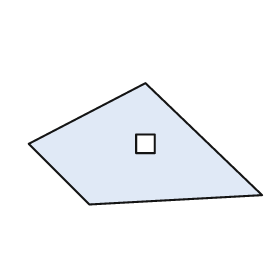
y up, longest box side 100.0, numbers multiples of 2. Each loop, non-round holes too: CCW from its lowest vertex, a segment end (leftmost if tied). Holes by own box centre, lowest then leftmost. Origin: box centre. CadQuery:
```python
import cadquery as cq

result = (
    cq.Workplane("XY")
    .moveTo(-24.0, -26.0)
    .lineTo(50.0, -22.0)
    .lineTo(0.0, 26.0)
    .lineTo(-50.0, 0.0)
    .close()
    .moveTo(-4.0, -4.0)
    .lineTo(4.0, -4.0)
    .lineTo(4.0, 4.0)
    .lineTo(-4.0, 4.0)
    .close()
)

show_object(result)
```